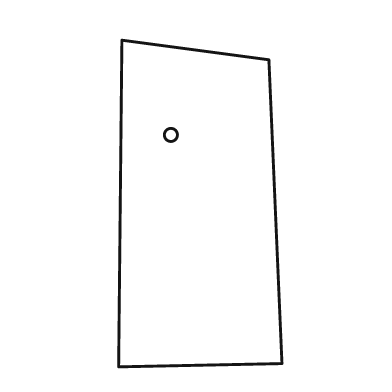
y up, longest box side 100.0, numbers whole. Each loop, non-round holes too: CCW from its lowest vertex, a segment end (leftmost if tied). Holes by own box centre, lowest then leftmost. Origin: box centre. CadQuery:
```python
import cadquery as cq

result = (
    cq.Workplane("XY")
    .moveTo(-25.0, -50.0)
    .lineTo(25.0, -49.0)
    .lineTo(21.0, 44.0)
    .lineTo(-24.0, 50.0)
    .close()
    .moveTo(-9.0, 21.0)
    .circle(2.0)
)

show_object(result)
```